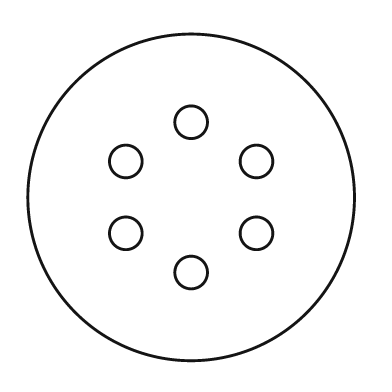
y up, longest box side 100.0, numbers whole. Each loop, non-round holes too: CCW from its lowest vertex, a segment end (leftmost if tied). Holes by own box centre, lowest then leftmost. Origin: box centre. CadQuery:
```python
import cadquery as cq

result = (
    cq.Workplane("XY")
    .moveTo(0.0, 0.0)
    .circle(50.0)
    .moveTo(0.0, -23.0)
    .circle(5.0)
    .moveTo(-20.0, -11.0)
    .circle(5.0)
    .moveTo(20.0, -11.0)
    .circle(5.0)
    .moveTo(-20.0, 11.0)
    .circle(5.0)
    .moveTo(20.0, 11.0)
    .circle(5.0)
    .moveTo(0.0, 23.0)
    .circle(5.0)
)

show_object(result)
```